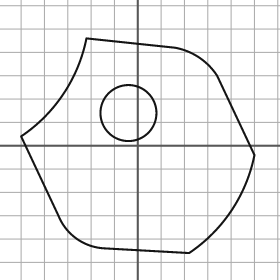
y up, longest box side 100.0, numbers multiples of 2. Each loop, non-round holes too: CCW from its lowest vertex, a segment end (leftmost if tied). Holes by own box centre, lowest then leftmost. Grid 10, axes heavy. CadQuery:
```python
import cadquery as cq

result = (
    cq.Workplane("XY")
    .moveTo(22.0, -46.0)
    .threePointArc((40.0, -28.0), (50.0, -4.0))
    .lineTo(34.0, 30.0)
    .threePointArc((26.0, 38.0), (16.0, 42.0))
    .lineTo(-22.0, 46.0)
    .threePointArc((-32.0, 22.0), (-50.0, 4.0))
    .lineTo(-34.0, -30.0)
    .threePointArc((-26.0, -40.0), (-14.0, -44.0))
    .close()
    .moveTo(-4.0, 14.0)
    .circle(12.0)
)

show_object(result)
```